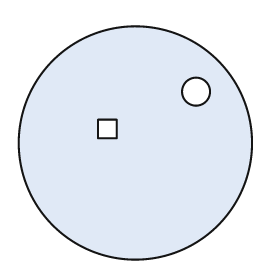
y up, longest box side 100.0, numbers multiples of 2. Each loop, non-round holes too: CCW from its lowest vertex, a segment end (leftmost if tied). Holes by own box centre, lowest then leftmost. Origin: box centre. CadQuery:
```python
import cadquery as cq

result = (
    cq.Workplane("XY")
    .moveTo(0.0, 0.0)
    .circle(50.0)
    .moveTo(-16.0, 2.0)
    .lineTo(-8.0, 2.0)
    .lineTo(-8.0, 10.0)
    .lineTo(-16.0, 10.0)
    .close()
    .moveTo(26.0, 22.0)
    .circle(6.0)
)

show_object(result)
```